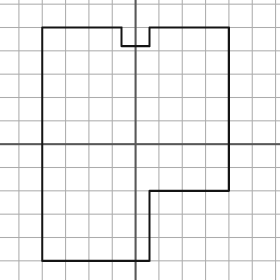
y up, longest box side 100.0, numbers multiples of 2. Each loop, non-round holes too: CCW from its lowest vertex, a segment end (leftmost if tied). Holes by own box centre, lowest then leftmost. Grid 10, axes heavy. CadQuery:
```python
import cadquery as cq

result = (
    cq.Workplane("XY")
    .moveTo(-40.0, -50.0)
    .lineTo(6.0, -50.0)
    .lineTo(6.0, -20.0)
    .lineTo(40.0, -20.0)
    .lineTo(40.0, 50.0)
    .lineTo(6.0, 50.0)
    .lineTo(6.0, 42.0)
    .lineTo(-6.0, 42.0)
    .lineTo(-6.0, 50.0)
    .lineTo(-40.0, 50.0)
    .close()
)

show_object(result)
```